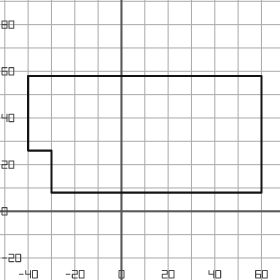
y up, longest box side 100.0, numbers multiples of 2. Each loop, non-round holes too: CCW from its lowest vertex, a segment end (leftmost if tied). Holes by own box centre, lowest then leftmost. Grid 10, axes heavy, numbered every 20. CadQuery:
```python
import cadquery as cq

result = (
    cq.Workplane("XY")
    .moveTo(-30.0, 8.0)
    .lineTo(60.0, 8.0)
    .lineTo(60.0, 58.0)
    .lineTo(-40.0, 58.0)
    .lineTo(-40.0, 26.0)
    .lineTo(-30.0, 26.0)
    .close()
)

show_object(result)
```